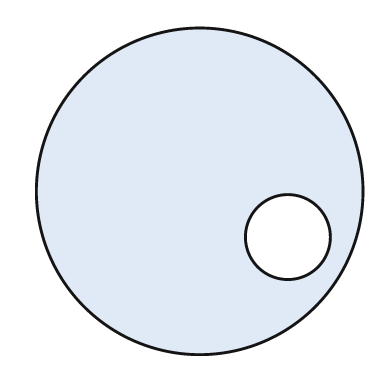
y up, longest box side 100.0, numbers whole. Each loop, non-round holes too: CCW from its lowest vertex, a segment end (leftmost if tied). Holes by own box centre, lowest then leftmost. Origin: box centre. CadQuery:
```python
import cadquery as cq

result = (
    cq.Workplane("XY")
    .moveTo(0.0, 0.0)
    .circle(50.0)
    .moveTo(27.0, -14.0)
    .circle(13.0)
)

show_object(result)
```